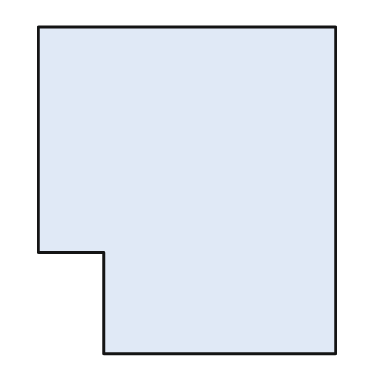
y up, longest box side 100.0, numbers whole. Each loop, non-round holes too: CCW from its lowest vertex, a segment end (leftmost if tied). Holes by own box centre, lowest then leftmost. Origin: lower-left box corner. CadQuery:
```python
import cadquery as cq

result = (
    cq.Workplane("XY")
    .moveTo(20.0, 0.0)
    .lineTo(91.0, 0.0)
    .lineTo(91.0, 100.0)
    .lineTo(0.0, 100.0)
    .lineTo(0.0, 31.0)
    .lineTo(20.0, 31.0)
    .close()
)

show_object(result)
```